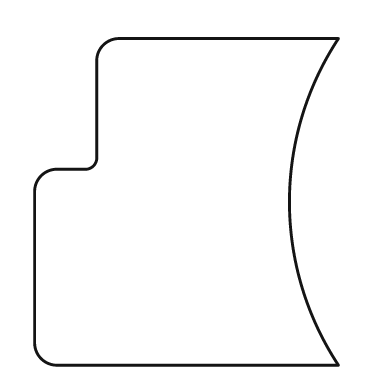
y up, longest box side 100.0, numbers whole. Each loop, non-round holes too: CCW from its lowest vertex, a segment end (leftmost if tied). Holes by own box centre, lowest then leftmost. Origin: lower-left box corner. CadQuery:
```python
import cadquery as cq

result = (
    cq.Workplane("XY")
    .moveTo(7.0, 0.0)
    .lineTo(93.0, 0.0)
    .threePointArc((78.0, 50.0), (93.0, 100.0))
    .lineTo(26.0, 100.0)
    .threePointArc((21.0, 98.0), (19.0, 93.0))
    .lineTo(19.0, 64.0)
    .threePointArc((18.0, 61.0), (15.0, 60.0))
    .lineTo(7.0, 60.0)
    .threePointArc((2.0, 58.0), (0.0, 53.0))
    .lineTo(0.0, 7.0)
    .threePointArc((2.0, 2.0), (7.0, 0.0))
    .close()
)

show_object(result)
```